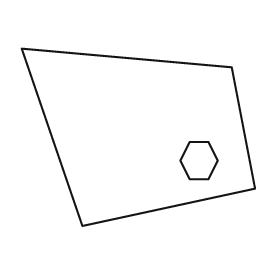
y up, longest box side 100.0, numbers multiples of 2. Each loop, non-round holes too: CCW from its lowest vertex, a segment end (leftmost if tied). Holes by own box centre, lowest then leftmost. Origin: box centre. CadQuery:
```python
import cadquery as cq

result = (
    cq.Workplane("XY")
    .moveTo(-24.0, -38.0)
    .lineTo(50.0, -22.0)
    .lineTo(40.0, 30.0)
    .lineTo(-50.0, 38.0)
    .close()
    .moveTo(22.0, -18.0)
    .lineTo(30.0, -18.0)
    .lineTo(34.0, -10.0)
    .lineTo(30.0, -2.0)
    .lineTo(22.0, -2.0)
    .lineTo(18.0, -10.0)
    .close()
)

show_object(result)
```